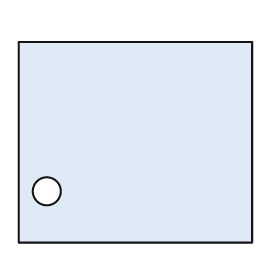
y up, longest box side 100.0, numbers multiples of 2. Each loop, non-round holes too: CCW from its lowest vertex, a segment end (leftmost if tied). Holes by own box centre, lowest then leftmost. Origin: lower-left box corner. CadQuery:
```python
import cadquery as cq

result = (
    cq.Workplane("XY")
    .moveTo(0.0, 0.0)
    .lineTo(100.0, 0.0)
    .lineTo(100.0, 86.0)
    .lineTo(0.0, 86.0)
    .close()
    .moveTo(12.0, 22.0)
    .circle(6.0)
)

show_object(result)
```